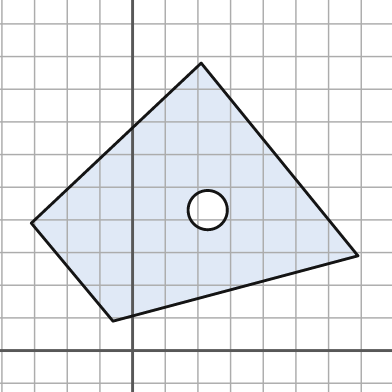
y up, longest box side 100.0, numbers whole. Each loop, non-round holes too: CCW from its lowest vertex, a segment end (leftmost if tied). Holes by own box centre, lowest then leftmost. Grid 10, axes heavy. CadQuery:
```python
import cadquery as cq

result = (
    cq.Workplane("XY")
    .moveTo(-6.0, 9.0)
    .lineTo(69.0, 29.0)
    .lineTo(21.0, 88.0)
    .lineTo(-31.0, 39.0)
    .close()
    .moveTo(23.0, 43.0)
    .circle(6.0)
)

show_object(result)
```